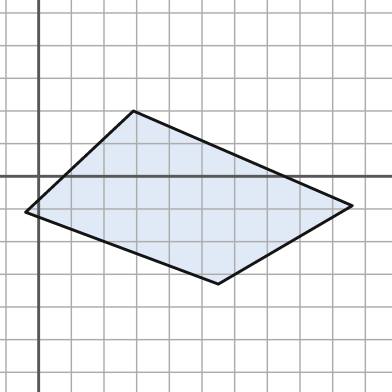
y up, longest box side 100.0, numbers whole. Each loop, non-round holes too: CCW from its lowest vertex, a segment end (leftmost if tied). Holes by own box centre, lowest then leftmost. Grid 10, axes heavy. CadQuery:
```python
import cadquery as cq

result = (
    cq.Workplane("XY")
    .moveTo(55.0, -33.0)
    .lineTo(96.0, -9.0)
    .lineTo(29.0, 20.0)
    .lineTo(-4.0, -11.0)
    .close()
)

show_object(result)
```